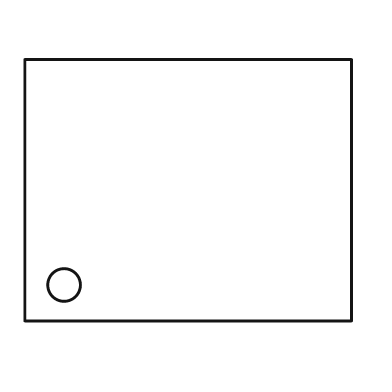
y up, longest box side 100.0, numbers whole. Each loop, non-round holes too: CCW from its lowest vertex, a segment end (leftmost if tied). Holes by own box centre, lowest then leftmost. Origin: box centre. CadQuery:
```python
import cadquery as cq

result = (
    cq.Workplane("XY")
    .moveTo(-50.0, -40.0)
    .lineTo(50.0, -40.0)
    .lineTo(50.0, 40.0)
    .lineTo(-50.0, 40.0)
    .close()
    .moveTo(-38.0, -29.0)
    .circle(5.0)
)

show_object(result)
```